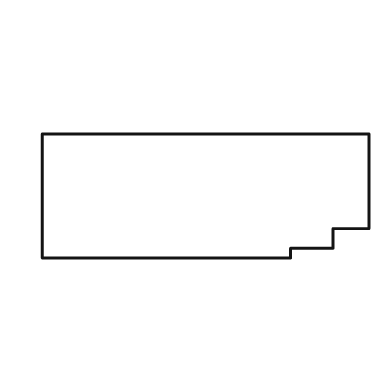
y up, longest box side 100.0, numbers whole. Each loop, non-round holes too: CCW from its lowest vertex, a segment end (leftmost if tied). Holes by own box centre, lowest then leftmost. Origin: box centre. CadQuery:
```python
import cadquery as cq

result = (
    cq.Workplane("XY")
    .moveTo(-50.0, -19.0)
    .lineTo(26.0, -19.0)
    .lineTo(26.0, -16.0)
    .lineTo(39.0, -16.0)
    .lineTo(39.0, -10.0)
    .lineTo(50.0, -10.0)
    .lineTo(50.0, 19.0)
    .lineTo(-50.0, 19.0)
    .close()
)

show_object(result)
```